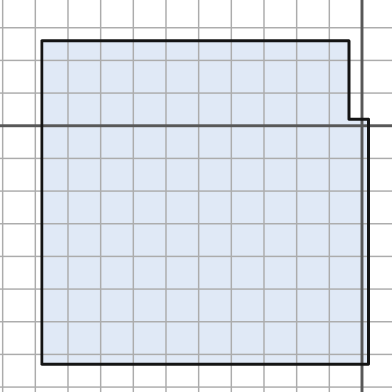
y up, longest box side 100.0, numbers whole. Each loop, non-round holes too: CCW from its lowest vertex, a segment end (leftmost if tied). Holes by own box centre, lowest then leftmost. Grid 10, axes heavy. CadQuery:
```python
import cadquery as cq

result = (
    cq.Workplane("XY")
    .moveTo(-98.0, -73.0)
    .lineTo(2.0, -73.0)
    .lineTo(2.0, 2.0)
    .lineTo(-4.0, 2.0)
    .lineTo(-4.0, 26.0)
    .lineTo(-98.0, 26.0)
    .close()
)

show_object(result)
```